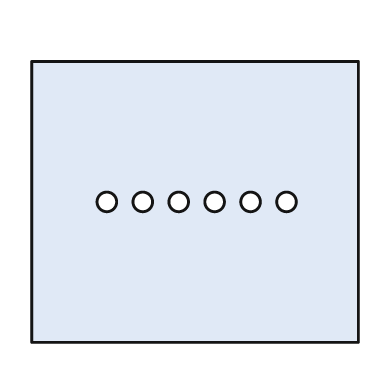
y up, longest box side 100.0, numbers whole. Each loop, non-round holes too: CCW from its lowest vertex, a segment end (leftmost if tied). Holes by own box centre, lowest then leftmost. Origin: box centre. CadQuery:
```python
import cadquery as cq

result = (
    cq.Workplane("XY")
    .moveTo(-50.0, -43.0)
    .lineTo(50.0, -43.0)
    .lineTo(50.0, 43.0)
    .lineTo(-50.0, 43.0)
    .close()
    .moveTo(-27.0, 0.0)
    .circle(3.0)
    .moveTo(-16.0, 0.0)
    .circle(3.0)
    .moveTo(-5.0, 0.0)
    .circle(3.0)
    .moveTo(6.0, 0.0)
    .circle(3.0)
    .moveTo(17.0, 0.0)
    .circle(3.0)
    .moveTo(28.0, 0.0)
    .circle(3.0)
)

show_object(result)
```